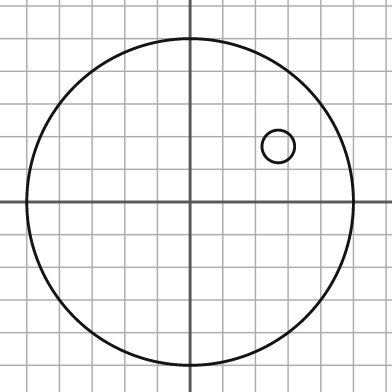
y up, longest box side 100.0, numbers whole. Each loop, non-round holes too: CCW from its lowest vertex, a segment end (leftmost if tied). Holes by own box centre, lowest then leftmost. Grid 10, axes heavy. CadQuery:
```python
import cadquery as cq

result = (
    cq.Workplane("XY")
    .moveTo(0.0, 0.0)
    .circle(50.0)
    .moveTo(27.0, 17.0)
    .circle(5.0)
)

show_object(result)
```